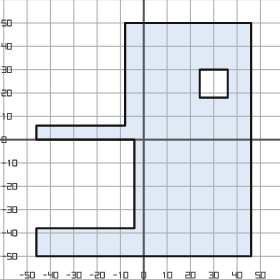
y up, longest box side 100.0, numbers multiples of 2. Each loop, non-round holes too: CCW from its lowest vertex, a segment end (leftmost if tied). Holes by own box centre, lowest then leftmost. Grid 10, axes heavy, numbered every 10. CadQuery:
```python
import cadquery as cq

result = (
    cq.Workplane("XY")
    .moveTo(-46.0, -50.0)
    .lineTo(46.0, -50.0)
    .lineTo(46.0, 50.0)
    .lineTo(-8.0, 50.0)
    .lineTo(-8.0, 6.0)
    .lineTo(-46.0, 6.0)
    .lineTo(-46.0, 0.0)
    .lineTo(-4.0, 0.0)
    .lineTo(-4.0, -38.0)
    .lineTo(-46.0, -38.0)
    .close()
    .moveTo(24.0, 18.0)
    .lineTo(36.0, 18.0)
    .lineTo(36.0, 30.0)
    .lineTo(24.0, 30.0)
    .close()
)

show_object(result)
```